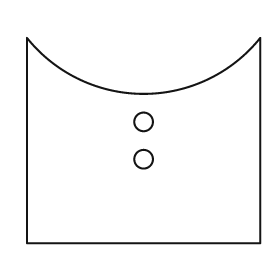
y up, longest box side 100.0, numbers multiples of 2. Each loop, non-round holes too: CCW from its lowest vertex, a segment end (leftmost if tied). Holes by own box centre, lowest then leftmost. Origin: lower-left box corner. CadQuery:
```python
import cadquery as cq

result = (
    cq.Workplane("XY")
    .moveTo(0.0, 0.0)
    .lineTo(100.0, 0.0)
    .lineTo(100.0, 88.0)
    .threePointArc((50.0, 64.0), (0.0, 88.0))
    .close()
    .moveTo(50.0, 36.0)
    .circle(4.0)
    .moveTo(50.0, 52.0)
    .circle(4.0)
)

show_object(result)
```